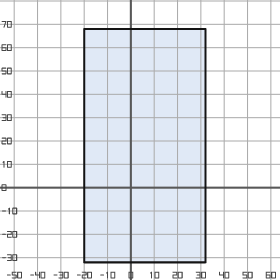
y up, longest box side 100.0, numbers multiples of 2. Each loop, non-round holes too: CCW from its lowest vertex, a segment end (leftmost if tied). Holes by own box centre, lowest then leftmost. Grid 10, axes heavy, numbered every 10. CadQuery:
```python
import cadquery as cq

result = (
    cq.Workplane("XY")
    .moveTo(-20.0, -32.0)
    .lineTo(32.0, -32.0)
    .lineTo(32.0, 68.0)
    .lineTo(-20.0, 68.0)
    .close()
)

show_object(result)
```